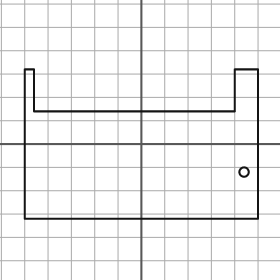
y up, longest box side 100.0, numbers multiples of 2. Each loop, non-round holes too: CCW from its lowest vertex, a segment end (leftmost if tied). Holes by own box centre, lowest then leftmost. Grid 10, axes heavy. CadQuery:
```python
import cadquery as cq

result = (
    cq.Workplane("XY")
    .moveTo(-50.0, -32.0)
    .lineTo(50.0, -32.0)
    .lineTo(50.0, 32.0)
    .lineTo(40.0, 32.0)
    .lineTo(40.0, 14.0)
    .lineTo(-46.0, 14.0)
    .lineTo(-46.0, 32.0)
    .lineTo(-50.0, 32.0)
    .close()
    .moveTo(44.0, -12.0)
    .circle(2.0)
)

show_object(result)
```